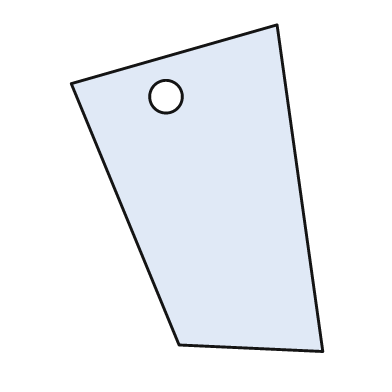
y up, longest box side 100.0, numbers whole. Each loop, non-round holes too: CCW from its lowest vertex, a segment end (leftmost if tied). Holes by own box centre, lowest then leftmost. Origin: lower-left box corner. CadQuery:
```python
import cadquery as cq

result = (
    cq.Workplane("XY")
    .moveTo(77.0, 0.0)
    .lineTo(63.0, 100.0)
    .lineTo(0.0, 82.0)
    .lineTo(33.0, 2.0)
    .close()
    .moveTo(29.0, 78.0)
    .circle(5.0)
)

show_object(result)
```